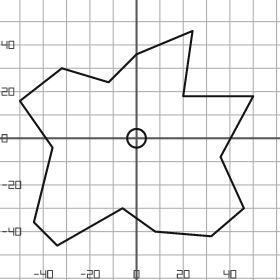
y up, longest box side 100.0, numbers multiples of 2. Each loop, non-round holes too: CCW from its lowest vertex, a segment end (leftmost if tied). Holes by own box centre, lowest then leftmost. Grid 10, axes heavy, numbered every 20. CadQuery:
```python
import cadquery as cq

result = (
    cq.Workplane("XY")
    .moveTo(-34.0, -46.0)
    .lineTo(-6.0, -30.0)
    .lineTo(8.0, -40.0)
    .lineTo(32.0, -42.0)
    .lineTo(46.0, -30.0)
    .lineTo(36.0, -8.0)
    .lineTo(50.0, 18.0)
    .lineTo(20.0, 18.0)
    .lineTo(24.0, 46.0)
    .lineTo(0.0, 36.0)
    .lineTo(-12.0, 24.0)
    .lineTo(-32.0, 30.0)
    .lineTo(-50.0, 16.0)
    .lineTo(-36.0, -4.0)
    .lineTo(-44.0, -36.0)
    .close()
    .moveTo(0.0, 0.0)
    .circle(4.0)
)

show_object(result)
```